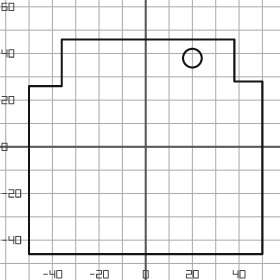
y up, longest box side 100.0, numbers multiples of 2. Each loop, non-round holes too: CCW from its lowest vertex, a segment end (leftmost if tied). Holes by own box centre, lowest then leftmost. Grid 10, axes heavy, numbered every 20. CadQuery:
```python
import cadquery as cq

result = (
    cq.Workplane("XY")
    .moveTo(-50.0, -46.0)
    .lineTo(50.0, -46.0)
    .lineTo(50.0, 28.0)
    .lineTo(38.0, 28.0)
    .lineTo(38.0, 46.0)
    .lineTo(-36.0, 46.0)
    .lineTo(-36.0, 26.0)
    .lineTo(-50.0, 26.0)
    .close()
    .moveTo(20.0, 38.0)
    .circle(4.0)
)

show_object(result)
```